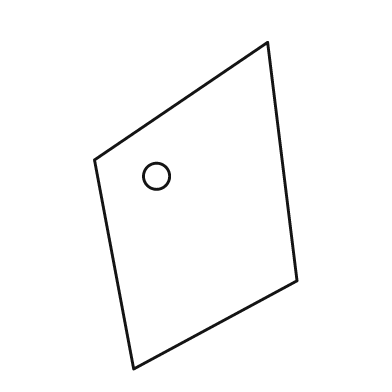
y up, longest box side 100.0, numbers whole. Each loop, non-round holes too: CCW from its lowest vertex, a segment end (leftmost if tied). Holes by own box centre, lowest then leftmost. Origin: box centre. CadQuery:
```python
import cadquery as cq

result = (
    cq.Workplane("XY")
    .moveTo(-19.0, -50.0)
    .lineTo(31.0, -23.0)
    .lineTo(22.0, 50.0)
    .lineTo(-31.0, 14.0)
    .close()
    .moveTo(-12.0, 9.0)
    .circle(4.0)
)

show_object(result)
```